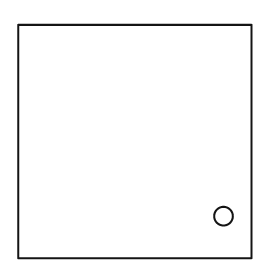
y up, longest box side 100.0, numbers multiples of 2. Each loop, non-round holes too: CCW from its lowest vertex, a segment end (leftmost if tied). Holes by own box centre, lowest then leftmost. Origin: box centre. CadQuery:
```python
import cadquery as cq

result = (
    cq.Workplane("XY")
    .moveTo(-50.0, -50.0)
    .lineTo(50.0, -50.0)
    .lineTo(50.0, 50.0)
    .lineTo(-50.0, 50.0)
    .close()
    .moveTo(38.0, -32.0)
    .circle(4.0)
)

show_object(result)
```